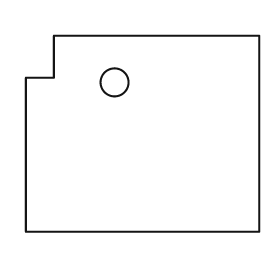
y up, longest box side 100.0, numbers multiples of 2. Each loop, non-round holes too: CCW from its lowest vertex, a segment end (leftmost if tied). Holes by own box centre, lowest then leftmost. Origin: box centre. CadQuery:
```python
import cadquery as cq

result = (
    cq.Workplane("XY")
    .moveTo(-50.0, -42.0)
    .lineTo(50.0, -42.0)
    .lineTo(50.0, 42.0)
    .lineTo(-38.0, 42.0)
    .lineTo(-38.0, 24.0)
    .lineTo(-50.0, 24.0)
    .close()
    .moveTo(-12.0, 22.0)
    .circle(6.0)
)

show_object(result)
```